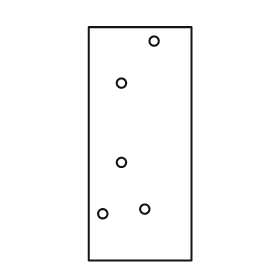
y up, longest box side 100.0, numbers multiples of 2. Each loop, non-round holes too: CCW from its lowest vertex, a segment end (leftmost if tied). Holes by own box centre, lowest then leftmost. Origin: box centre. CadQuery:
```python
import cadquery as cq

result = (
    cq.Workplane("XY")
    .moveTo(-22.0, -50.0)
    .lineTo(22.0, -50.0)
    .lineTo(22.0, 50.0)
    .lineTo(-22.0, 50.0)
    .close()
    .moveTo(-16.0, -30.0)
    .circle(2.0)
    .moveTo(2.0, -28.0)
    .circle(2.0)
    .moveTo(-8.0, -8.0)
    .circle(2.0)
    .moveTo(-8.0, 26.0)
    .circle(2.0)
    .moveTo(6.0, 44.0)
    .circle(2.0)
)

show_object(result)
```